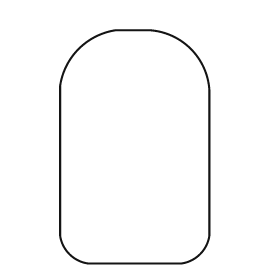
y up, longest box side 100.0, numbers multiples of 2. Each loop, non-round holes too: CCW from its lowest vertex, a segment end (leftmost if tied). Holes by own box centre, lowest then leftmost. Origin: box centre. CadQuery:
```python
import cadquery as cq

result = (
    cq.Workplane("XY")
    .moveTo(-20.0, -50.0)
    .lineTo(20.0, -50.0)
    .threePointArc((28.0, -46.0), (32.0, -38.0))
    .lineTo(32.0, 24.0)
    .threePointArc((24.0, 42.0), (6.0, 50.0))
    .lineTo(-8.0, 50.0)
    .threePointArc((-24.0, 42.0), (-32.0, 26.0))
    .lineTo(-32.0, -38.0)
    .threePointArc((-28.0, -46.0), (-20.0, -50.0))
    .close()
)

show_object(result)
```